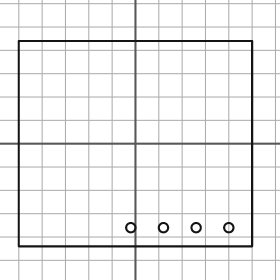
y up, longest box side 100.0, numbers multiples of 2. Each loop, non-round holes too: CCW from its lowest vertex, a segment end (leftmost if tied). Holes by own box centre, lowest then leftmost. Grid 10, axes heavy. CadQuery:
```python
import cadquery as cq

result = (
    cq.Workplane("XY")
    .moveTo(-50.0, -44.0)
    .lineTo(50.0, -44.0)
    .lineTo(50.0, 44.0)
    .lineTo(-50.0, 44.0)
    .close()
    .moveTo(-2.0, -36.0)
    .circle(2.0)
    .moveTo(12.0, -36.0)
    .circle(2.0)
    .moveTo(26.0, -36.0)
    .circle(2.0)
    .moveTo(40.0, -36.0)
    .circle(2.0)
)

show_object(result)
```